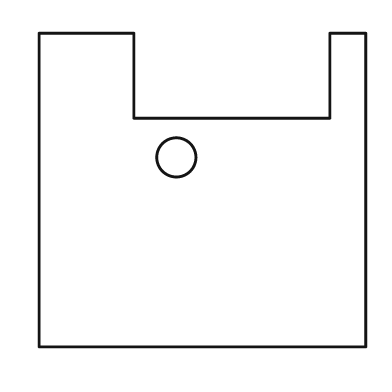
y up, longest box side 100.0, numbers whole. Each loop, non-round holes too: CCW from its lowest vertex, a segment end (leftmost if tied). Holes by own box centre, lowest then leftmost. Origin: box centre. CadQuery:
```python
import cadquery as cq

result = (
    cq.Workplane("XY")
    .moveTo(-50.0, -48.0)
    .lineTo(50.0, -48.0)
    .lineTo(50.0, 48.0)
    .lineTo(39.0, 48.0)
    .lineTo(39.0, 22.0)
    .lineTo(-21.0, 22.0)
    .lineTo(-21.0, 48.0)
    .lineTo(-50.0, 48.0)
    .close()
    .moveTo(-8.0, 10.0)
    .circle(6.0)
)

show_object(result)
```